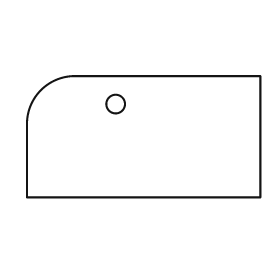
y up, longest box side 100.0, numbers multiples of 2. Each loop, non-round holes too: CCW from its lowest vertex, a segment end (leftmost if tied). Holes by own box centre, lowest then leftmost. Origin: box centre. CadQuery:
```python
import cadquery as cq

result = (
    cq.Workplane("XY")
    .moveTo(-50.0, -26.0)
    .lineTo(50.0, -26.0)
    .lineTo(50.0, 26.0)
    .lineTo(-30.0, 26.0)
    .threePointArc((-44.0, 20.0), (-50.0, 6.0))
    .close()
    .moveTo(-12.0, 14.0)
    .circle(4.0)
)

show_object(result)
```